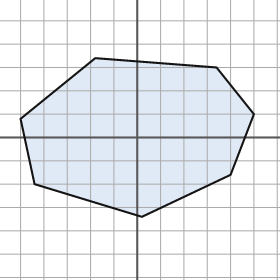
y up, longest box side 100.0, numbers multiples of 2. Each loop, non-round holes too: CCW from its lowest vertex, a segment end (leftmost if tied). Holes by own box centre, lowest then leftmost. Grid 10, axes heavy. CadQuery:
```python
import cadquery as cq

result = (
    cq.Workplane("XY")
    .moveTo(2.0, -34.0)
    .lineTo(40.0, -16.0)
    .lineTo(50.0, 10.0)
    .lineTo(34.0, 30.0)
    .lineTo(-18.0, 34.0)
    .lineTo(-50.0, 8.0)
    .lineTo(-44.0, -20.0)
    .close()
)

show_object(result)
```